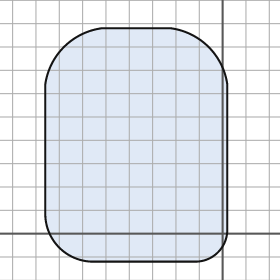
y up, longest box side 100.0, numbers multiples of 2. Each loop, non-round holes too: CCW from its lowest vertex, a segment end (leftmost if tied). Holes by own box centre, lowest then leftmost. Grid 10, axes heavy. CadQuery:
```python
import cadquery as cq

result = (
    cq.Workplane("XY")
    .moveTo(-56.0, -12.0)
    .lineTo(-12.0, -12.0)
    .threePointArc((-2.0, -8.0), (2.0, 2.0))
    .lineTo(2.0, 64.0)
    .threePointArc((-6.0, 80.0), (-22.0, 88.0))
    .lineTo(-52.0, 88.0)
    .threePointArc((-68.0, 80.0), (-76.0, 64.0))
    .lineTo(-76.0, 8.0)
    .threePointArc((-70.0, -6.0), (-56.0, -12.0))
    .close()
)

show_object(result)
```